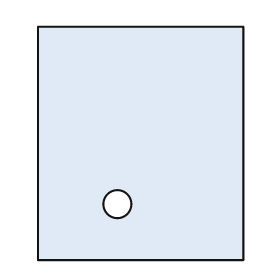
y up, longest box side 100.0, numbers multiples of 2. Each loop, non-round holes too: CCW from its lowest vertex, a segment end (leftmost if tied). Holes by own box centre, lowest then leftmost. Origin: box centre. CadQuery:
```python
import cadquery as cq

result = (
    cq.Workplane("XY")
    .moveTo(-44.0, -50.0)
    .lineTo(44.0, -50.0)
    .lineTo(44.0, 50.0)
    .lineTo(-44.0, 50.0)
    .close()
    .moveTo(-10.0, -26.0)
    .circle(6.0)
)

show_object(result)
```